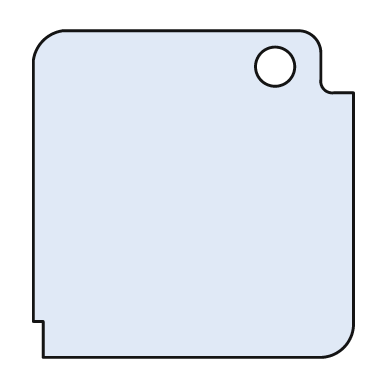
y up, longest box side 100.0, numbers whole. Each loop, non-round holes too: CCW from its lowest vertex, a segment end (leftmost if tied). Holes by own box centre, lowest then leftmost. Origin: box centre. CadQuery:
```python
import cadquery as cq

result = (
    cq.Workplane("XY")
    .moveTo(-46.0, -50.0)
    .lineTo(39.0, -50.0)
    .threePointArc((46.0, -47.0), (49.0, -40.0))
    .lineTo(49.0, 31.0)
    .lineTo(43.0, 31.0)
    .threePointArc((40.0, 32.0), (39.0, 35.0))
    .lineTo(39.0, 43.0)
    .threePointArc((37.0, 48.0), (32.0, 50.0))
    .lineTo(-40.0, 50.0)
    .threePointArc((-46.0, 47.0), (-49.0, 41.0))
    .lineTo(-49.0, -39.0)
    .lineTo(-46.0, -39.0)
    .close()
    .moveTo(25.0, 39.0)
    .circle(6.0)
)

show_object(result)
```